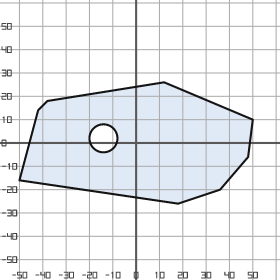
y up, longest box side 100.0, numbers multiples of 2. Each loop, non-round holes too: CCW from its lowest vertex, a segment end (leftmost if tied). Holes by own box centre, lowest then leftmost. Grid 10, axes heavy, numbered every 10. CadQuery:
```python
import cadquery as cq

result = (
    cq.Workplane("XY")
    .moveTo(18.0, -26.0)
    .lineTo(36.0, -20.0)
    .lineTo(48.0, -6.0)
    .lineTo(50.0, 10.0)
    .lineTo(12.0, 26.0)
    .lineTo(-38.0, 18.0)
    .lineTo(-42.0, 14.0)
    .lineTo(-50.0, -16.0)
    .close()
    .moveTo(-14.0, 2.0)
    .circle(6.0)
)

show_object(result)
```